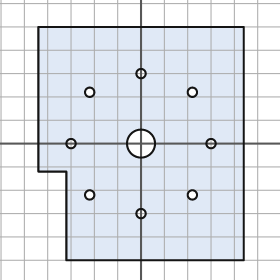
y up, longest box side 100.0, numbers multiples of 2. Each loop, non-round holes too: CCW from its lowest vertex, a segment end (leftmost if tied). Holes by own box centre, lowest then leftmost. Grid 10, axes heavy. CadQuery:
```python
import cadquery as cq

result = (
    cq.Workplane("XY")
    .moveTo(-32.0, -50.0)
    .lineTo(44.0, -50.0)
    .lineTo(44.0, 50.0)
    .lineTo(-44.0, 50.0)
    .lineTo(-44.0, -12.0)
    .lineTo(-32.0, -12.0)
    .close()
    .moveTo(0.0, -30.0)
    .circle(2.0)
    .moveTo(-22.0, -22.0)
    .circle(2.0)
    .moveTo(22.0, -22.0)
    .circle(2.0)
    .moveTo(-30.0, 0.0)
    .circle(2.0)
    .moveTo(0.0, 0.0)
    .circle(6.0)
    .moveTo(30.0, 0.0)
    .circle(2.0)
    .moveTo(-22.0, 22.0)
    .circle(2.0)
    .moveTo(22.0, 22.0)
    .circle(2.0)
    .moveTo(0.0, 30.0)
    .circle(2.0)
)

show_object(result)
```